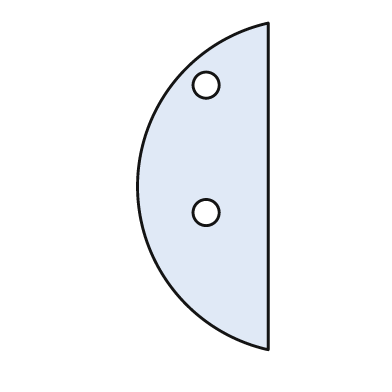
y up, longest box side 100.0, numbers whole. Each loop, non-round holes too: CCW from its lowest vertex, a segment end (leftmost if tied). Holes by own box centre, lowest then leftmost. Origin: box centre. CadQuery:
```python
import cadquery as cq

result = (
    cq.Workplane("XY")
    .moveTo(20.0, -50.0)
    .lineTo(20.0, 50.0)
    .threePointArc((-20.0, 0.0), (20.0, -50.0))
    .close()
    .moveTo(1.0, -8.0)
    .circle(4.0)
    .moveTo(1.0, 31.0)
    .circle(4.0)
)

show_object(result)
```